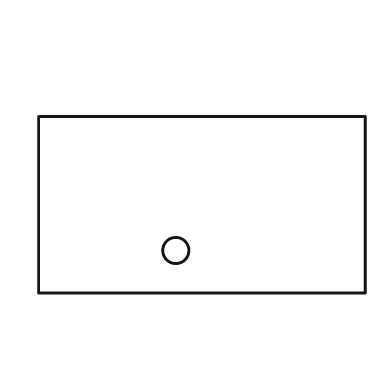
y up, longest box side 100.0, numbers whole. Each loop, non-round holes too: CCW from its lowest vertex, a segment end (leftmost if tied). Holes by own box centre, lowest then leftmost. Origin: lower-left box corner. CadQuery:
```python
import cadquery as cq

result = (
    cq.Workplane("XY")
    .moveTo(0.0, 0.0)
    .lineTo(100.0, 0.0)
    .lineTo(100.0, 54.0)
    .lineTo(0.0, 54.0)
    .close()
    .moveTo(42.0, 13.0)
    .circle(4.0)
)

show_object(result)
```